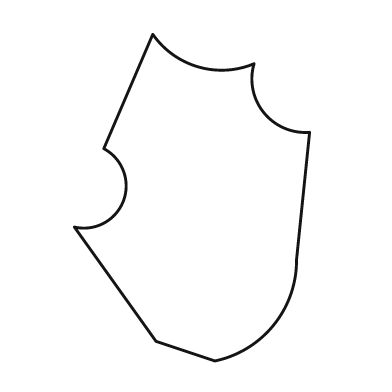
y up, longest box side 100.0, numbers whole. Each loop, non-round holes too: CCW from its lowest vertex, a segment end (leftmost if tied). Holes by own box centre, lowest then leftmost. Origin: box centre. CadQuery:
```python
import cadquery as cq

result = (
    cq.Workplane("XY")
    .moveTo(7.0, -50.0)
    .threePointArc((25.0, -39.0), (32.0, -19.0))
    .lineTo(36.0, 20.0)
    .threePointArc((22.0, 26.0), (19.0, 41.0))
    .threePointArc((2.0, 40.0), (-12.0, 50.0))
    .lineTo(-27.0, 15.0)
    .threePointArc((-21.0, -1.0), (-36.0, -9.0))
    .lineTo(-11.0, -44.0)
    .close()
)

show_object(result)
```